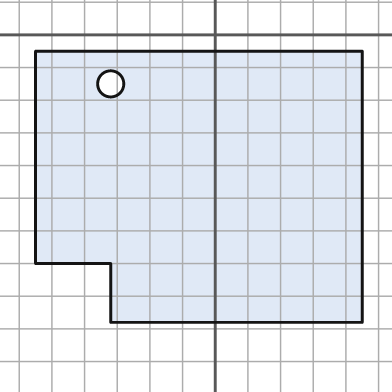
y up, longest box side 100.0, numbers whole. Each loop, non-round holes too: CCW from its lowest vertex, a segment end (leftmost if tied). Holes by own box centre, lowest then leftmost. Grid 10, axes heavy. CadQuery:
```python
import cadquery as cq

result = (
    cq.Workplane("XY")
    .moveTo(-32.0, -88.0)
    .lineTo(45.0, -88.0)
    .lineTo(45.0, -5.0)
    .lineTo(-55.0, -5.0)
    .lineTo(-55.0, -70.0)
    .lineTo(-32.0, -70.0)
    .close()
    .moveTo(-32.0, -15.0)
    .circle(4.0)
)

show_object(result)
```